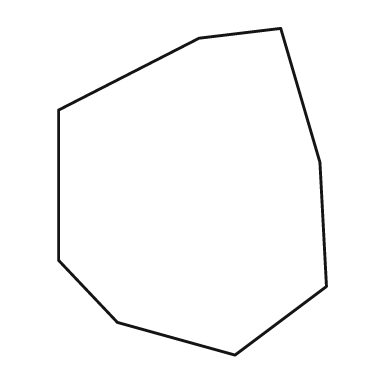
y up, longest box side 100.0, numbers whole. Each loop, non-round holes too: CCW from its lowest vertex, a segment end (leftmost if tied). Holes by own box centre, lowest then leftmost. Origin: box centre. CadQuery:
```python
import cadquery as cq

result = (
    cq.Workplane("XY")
    .moveTo(13.0, -50.0)
    .lineTo(41.0, -29.0)
    .lineTo(39.0, 9.0)
    .lineTo(27.0, 50.0)
    .lineTo(2.0, 47.0)
    .lineTo(-41.0, 25.0)
    .lineTo(-41.0, -21.0)
    .lineTo(-23.0, -40.0)
    .close()
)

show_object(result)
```